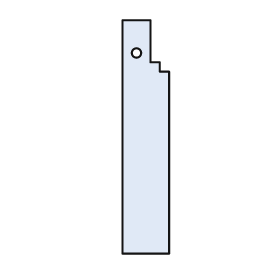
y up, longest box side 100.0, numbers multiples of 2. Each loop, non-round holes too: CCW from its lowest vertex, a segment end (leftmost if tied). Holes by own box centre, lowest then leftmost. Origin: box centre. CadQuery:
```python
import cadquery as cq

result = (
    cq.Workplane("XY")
    .moveTo(-10.0, -50.0)
    .lineTo(10.0, -50.0)
    .lineTo(10.0, 28.0)
    .lineTo(6.0, 28.0)
    .lineTo(6.0, 32.0)
    .lineTo(2.0, 32.0)
    .lineTo(2.0, 50.0)
    .lineTo(-10.0, 50.0)
    .close()
    .moveTo(-4.0, 36.0)
    .circle(2.0)
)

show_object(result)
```